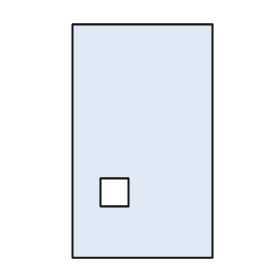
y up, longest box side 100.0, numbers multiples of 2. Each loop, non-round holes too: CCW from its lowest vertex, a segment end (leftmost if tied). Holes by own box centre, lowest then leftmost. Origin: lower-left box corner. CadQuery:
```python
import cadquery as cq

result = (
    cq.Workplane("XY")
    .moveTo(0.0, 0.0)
    .lineTo(60.0, 0.0)
    .lineTo(60.0, 100.0)
    .lineTo(0.0, 100.0)
    .close()
    .moveTo(12.0, 22.0)
    .lineTo(24.0, 22.0)
    .lineTo(24.0, 34.0)
    .lineTo(12.0, 34.0)
    .close()
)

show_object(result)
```